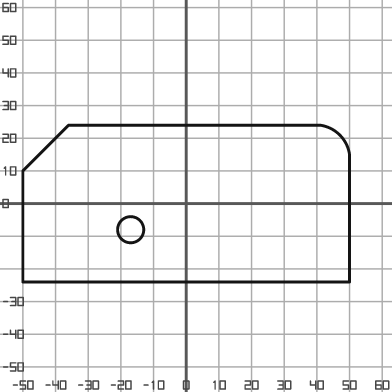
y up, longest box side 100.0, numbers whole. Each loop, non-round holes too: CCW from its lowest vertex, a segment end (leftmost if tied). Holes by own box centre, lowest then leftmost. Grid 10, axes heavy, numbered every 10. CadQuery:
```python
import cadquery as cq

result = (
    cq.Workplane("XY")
    .moveTo(-50.0, -24.0)
    .lineTo(50.0, -24.0)
    .lineTo(50.0, 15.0)
    .threePointArc((47.0, 21.0), (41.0, 24.0))
    .lineTo(-36.0, 24.0)
    .lineTo(-50.0, 10.0)
    .close()
    .moveTo(-17.0, -8.0)
    .circle(4.0)
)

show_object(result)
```